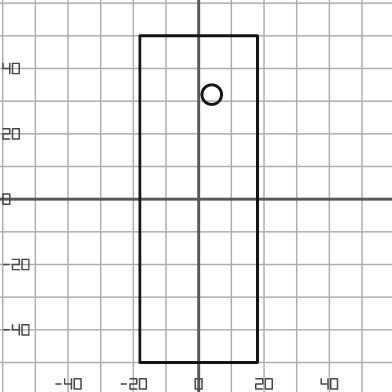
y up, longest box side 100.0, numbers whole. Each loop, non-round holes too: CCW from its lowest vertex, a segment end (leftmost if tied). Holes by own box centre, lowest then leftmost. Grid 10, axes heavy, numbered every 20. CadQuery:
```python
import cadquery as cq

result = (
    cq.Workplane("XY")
    .moveTo(-18.0, -50.0)
    .lineTo(18.0, -50.0)
    .lineTo(18.0, 50.0)
    .lineTo(-18.0, 50.0)
    .close()
    .moveTo(4.0, 32.0)
    .circle(3.0)
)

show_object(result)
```